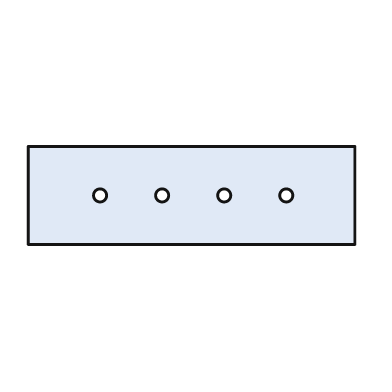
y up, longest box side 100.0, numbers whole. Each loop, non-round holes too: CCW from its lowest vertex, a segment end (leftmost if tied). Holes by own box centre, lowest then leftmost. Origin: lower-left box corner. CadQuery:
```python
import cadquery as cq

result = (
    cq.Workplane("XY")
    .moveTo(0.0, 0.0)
    .lineTo(100.0, 0.0)
    .lineTo(100.0, 30.0)
    .lineTo(0.0, 30.0)
    .close()
    .moveTo(22.0, 15.0)
    .circle(2.0)
    .moveTo(41.0, 15.0)
    .circle(2.0)
    .moveTo(60.0, 15.0)
    .circle(2.0)
    .moveTo(79.0, 15.0)
    .circle(2.0)
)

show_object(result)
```